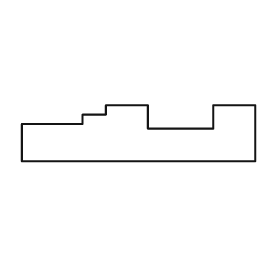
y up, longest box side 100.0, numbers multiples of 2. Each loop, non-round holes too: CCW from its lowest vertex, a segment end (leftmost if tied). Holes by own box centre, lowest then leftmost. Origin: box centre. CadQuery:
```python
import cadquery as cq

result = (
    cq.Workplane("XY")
    .moveTo(-50.0, -12.0)
    .lineTo(50.0, -12.0)
    .lineTo(50.0, 12.0)
    .lineTo(32.0, 12.0)
    .lineTo(32.0, 2.0)
    .lineTo(4.0, 2.0)
    .lineTo(4.0, 12.0)
    .lineTo(-14.0, 12.0)
    .lineTo(-14.0, 8.0)
    .lineTo(-24.0, 8.0)
    .lineTo(-24.0, 4.0)
    .lineTo(-50.0, 4.0)
    .close()
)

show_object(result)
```